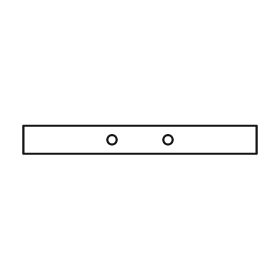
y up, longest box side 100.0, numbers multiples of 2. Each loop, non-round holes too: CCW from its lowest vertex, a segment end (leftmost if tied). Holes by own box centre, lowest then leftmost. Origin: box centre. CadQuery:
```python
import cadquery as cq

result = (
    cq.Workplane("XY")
    .moveTo(-50.0, -6.0)
    .lineTo(50.0, -6.0)
    .lineTo(50.0, 6.0)
    .lineTo(-50.0, 6.0)
    .close()
    .moveTo(-12.0, 0.0)
    .circle(2.0)
    .moveTo(12.0, 0.0)
    .circle(2.0)
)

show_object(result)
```